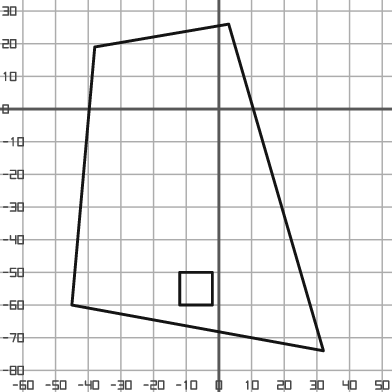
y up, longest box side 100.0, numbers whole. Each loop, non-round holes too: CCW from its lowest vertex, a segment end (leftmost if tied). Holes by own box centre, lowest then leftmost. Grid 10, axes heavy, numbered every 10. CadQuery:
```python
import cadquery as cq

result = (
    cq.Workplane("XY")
    .moveTo(32.0, -74.0)
    .lineTo(3.0, 26.0)
    .lineTo(-38.0, 19.0)
    .lineTo(-45.0, -60.0)
    .close()
    .moveTo(-12.0, -60.0)
    .lineTo(-2.0, -60.0)
    .lineTo(-2.0, -50.0)
    .lineTo(-12.0, -50.0)
    .close()
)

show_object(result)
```